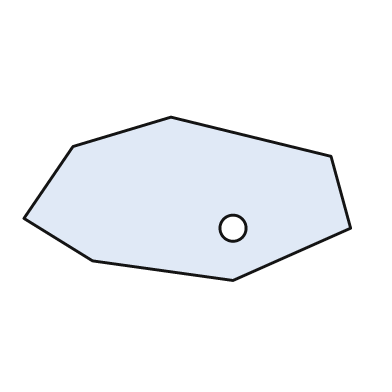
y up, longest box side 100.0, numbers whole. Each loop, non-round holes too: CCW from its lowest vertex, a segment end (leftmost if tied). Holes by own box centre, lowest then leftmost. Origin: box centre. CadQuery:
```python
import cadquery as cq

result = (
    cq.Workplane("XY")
    .moveTo(14.0, -25.0)
    .lineTo(50.0, -9.0)
    .lineTo(44.0, 13.0)
    .lineTo(-5.0, 25.0)
    .lineTo(-35.0, 16.0)
    .lineTo(-50.0, -6.0)
    .lineTo(-29.0, -19.0)
    .close()
    .moveTo(14.0, -9.0)
    .circle(4.0)
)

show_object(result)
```